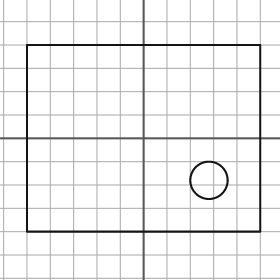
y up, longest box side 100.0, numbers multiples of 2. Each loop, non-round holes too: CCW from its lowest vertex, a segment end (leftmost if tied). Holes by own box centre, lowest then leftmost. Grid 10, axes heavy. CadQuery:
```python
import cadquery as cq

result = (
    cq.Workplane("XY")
    .moveTo(-50.0, -40.0)
    .lineTo(50.0, -40.0)
    .lineTo(50.0, 40.0)
    .lineTo(-50.0, 40.0)
    .close()
    .moveTo(28.0, -18.0)
    .circle(8.0)
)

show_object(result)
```